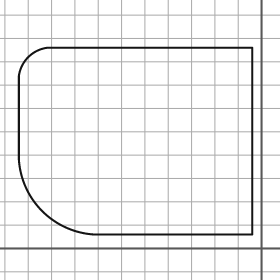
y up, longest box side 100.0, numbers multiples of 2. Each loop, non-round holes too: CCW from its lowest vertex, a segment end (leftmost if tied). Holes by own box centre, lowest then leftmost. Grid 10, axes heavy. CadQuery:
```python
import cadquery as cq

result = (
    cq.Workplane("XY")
    .moveTo(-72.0, 6.0)
    .lineTo(-4.0, 6.0)
    .lineTo(-4.0, 86.0)
    .lineTo(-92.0, 86.0)
    .threePointArc((-100.0, 82.0), (-104.0, 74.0))
    .lineTo(-104.0, 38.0)
    .threePointArc((-94.0, 16.0), (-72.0, 6.0))
    .close()
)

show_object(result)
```